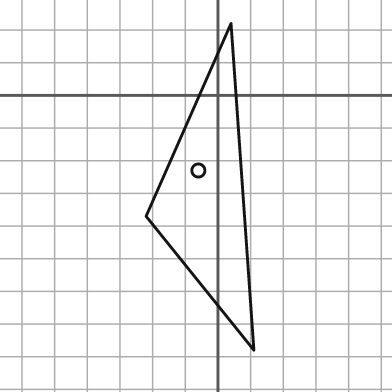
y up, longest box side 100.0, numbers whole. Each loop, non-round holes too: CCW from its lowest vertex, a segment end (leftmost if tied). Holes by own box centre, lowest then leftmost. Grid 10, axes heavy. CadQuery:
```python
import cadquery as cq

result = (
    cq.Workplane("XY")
    .moveTo(11.0, -78.0)
    .lineTo(4.0, 22.0)
    .lineTo(-22.0, -37.0)
    .close()
    .moveTo(-6.0, -23.0)
    .circle(2.0)
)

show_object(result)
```